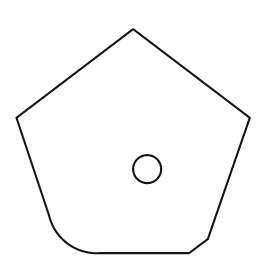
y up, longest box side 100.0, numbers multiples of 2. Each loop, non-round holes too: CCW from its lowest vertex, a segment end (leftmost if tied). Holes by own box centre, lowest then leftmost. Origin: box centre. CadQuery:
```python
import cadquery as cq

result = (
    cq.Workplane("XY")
    .moveTo(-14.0, -48.0)
    .lineTo(24.0, -48.0)
    .lineTo(32.0, -42.0)
    .lineTo(50.0, 10.0)
    .lineTo(0.0, 48.0)
    .lineTo(-50.0, 10.0)
    .lineTo(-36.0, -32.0)
    .threePointArc((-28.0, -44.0), (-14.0, -48.0))
    .close()
    .moveTo(6.0, -12.0)
    .circle(6.0)
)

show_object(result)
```